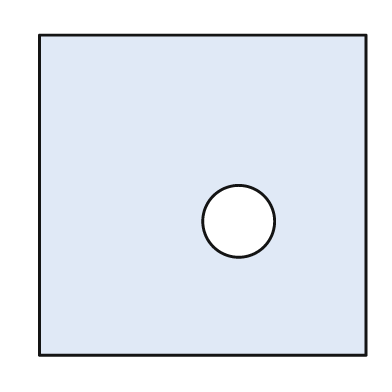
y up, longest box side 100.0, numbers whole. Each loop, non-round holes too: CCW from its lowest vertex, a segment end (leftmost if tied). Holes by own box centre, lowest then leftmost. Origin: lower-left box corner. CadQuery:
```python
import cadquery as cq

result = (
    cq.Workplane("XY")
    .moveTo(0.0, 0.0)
    .lineTo(100.0, 0.0)
    .lineTo(100.0, 98.0)
    .lineTo(0.0, 98.0)
    .close()
    .moveTo(61.0, 41.0)
    .circle(11.0)
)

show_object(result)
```